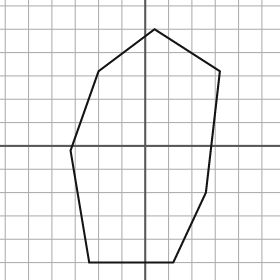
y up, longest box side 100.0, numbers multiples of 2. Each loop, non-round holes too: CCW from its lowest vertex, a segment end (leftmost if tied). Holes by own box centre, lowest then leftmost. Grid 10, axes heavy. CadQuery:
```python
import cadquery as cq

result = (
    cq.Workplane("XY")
    .moveTo(-24.0, -50.0)
    .lineTo(12.0, -50.0)
    .lineTo(26.0, -20.0)
    .lineTo(32.0, 32.0)
    .lineTo(4.0, 50.0)
    .lineTo(-20.0, 32.0)
    .lineTo(-32.0, -2.0)
    .close()
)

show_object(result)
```